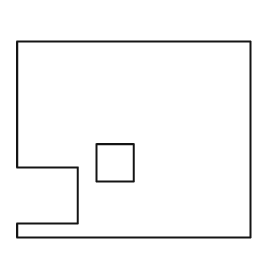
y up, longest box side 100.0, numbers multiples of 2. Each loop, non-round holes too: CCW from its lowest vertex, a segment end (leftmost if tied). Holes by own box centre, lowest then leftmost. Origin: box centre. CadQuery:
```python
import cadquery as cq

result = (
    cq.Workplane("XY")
    .moveTo(-50.0, -42.0)
    .lineTo(50.0, -42.0)
    .lineTo(50.0, 42.0)
    .lineTo(-50.0, 42.0)
    .lineTo(-50.0, -12.0)
    .lineTo(-24.0, -12.0)
    .lineTo(-24.0, -36.0)
    .lineTo(-50.0, -36.0)
    .close()
    .moveTo(-16.0, -18.0)
    .lineTo(0.0, -18.0)
    .lineTo(0.0, -2.0)
    .lineTo(-16.0, -2.0)
    .close()
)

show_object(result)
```